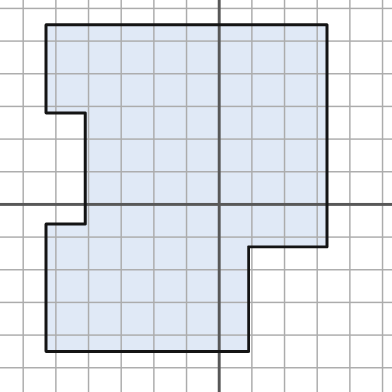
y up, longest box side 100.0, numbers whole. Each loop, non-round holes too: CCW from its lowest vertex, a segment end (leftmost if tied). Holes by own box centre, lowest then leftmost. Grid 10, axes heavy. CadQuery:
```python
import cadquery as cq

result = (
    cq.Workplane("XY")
    .moveTo(-53.0, -45.0)
    .lineTo(9.0, -45.0)
    .lineTo(9.0, -13.0)
    .lineTo(33.0, -13.0)
    .lineTo(33.0, 55.0)
    .lineTo(-53.0, 55.0)
    .lineTo(-53.0, 28.0)
    .lineTo(-41.0, 28.0)
    .lineTo(-41.0, -6.0)
    .lineTo(-53.0, -6.0)
    .close()
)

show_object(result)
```